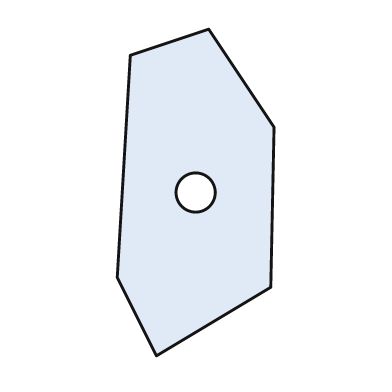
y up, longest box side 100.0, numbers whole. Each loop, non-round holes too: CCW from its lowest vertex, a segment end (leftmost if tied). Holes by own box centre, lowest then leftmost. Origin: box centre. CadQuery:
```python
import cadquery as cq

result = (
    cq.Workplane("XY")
    .moveTo(-12.0, -50.0)
    .lineTo(23.0, -29.0)
    .lineTo(24.0, 20.0)
    .lineTo(4.0, 50.0)
    .lineTo(-20.0, 42.0)
    .lineTo(-24.0, -26.0)
    .close()
    .moveTo(0.0, 0.0)
    .circle(6.0)
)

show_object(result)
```